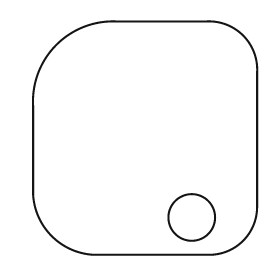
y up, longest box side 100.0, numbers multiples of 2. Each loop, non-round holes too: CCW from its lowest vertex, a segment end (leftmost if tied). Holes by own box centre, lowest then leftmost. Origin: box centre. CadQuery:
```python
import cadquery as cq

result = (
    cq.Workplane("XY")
    .moveTo(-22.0, -50.0)
    .lineTo(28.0, -50.0)
    .threePointArc((42.0, -44.0), (48.0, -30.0))
    .lineTo(48.0, 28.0)
    .threePointArc((42.0, 44.0), (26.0, 50.0))
    .lineTo(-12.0, 50.0)
    .threePointArc((-38.0, 40.0), (-48.0, 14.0))
    .lineTo(-48.0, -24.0)
    .threePointArc((-40.0, -42.0), (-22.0, -50.0))
    .close()
    .moveTo(20.0, -34.0)
    .circle(10.0)
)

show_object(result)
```